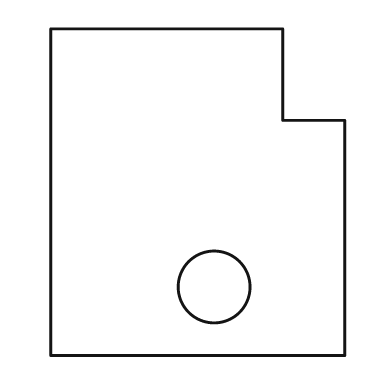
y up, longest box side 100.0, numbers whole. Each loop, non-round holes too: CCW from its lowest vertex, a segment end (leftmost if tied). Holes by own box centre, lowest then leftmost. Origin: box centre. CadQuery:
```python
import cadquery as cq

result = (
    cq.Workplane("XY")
    .moveTo(-45.0, -50.0)
    .lineTo(45.0, -50.0)
    .lineTo(45.0, 22.0)
    .lineTo(26.0, 22.0)
    .lineTo(26.0, 50.0)
    .lineTo(-45.0, 50.0)
    .close()
    .moveTo(5.0, -29.0)
    .circle(11.0)
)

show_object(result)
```